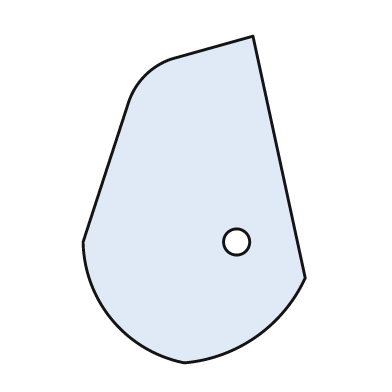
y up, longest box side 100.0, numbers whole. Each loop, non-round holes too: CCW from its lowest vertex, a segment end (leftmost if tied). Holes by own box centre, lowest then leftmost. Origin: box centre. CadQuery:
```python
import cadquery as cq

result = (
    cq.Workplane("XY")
    .moveTo(-3.0, -50.0)
    .threePointArc((19.0, -42.0), (34.0, -24.0))
    .lineTo(18.0, 50.0)
    .lineTo(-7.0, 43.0)
    .threePointArc((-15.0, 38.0), (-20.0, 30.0))
    .lineTo(-34.0, -13.0)
    .threePointArc((-25.0, -37.0), (-3.0, -50.0))
    .close()
    .moveTo(13.0, -13.0)
    .circle(4.0)
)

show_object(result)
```